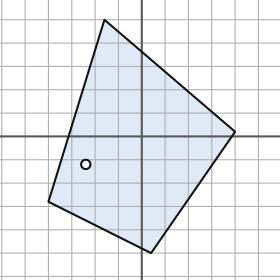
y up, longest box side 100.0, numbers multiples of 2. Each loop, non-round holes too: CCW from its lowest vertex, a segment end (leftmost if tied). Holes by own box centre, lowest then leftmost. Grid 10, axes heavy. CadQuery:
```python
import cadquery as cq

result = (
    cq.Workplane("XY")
    .moveTo(4.0, -50.0)
    .lineTo(40.0, 2.0)
    .lineTo(-16.0, 50.0)
    .lineTo(-40.0, -28.0)
    .close()
    .moveTo(-24.0, -12.0)
    .circle(2.0)
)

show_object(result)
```